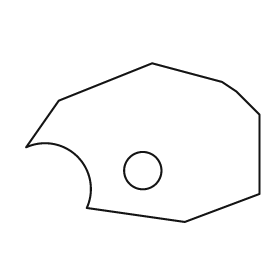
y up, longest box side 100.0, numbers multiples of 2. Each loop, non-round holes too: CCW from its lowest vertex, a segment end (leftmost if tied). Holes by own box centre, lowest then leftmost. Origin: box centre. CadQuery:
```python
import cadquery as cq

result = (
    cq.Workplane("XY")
    .moveTo(18.0, -34.0)
    .lineTo(50.0, -22.0)
    .lineTo(50.0, 12.0)
    .lineTo(40.0, 22.0)
    .lineTo(34.0, 26.0)
    .lineTo(4.0, 34.0)
    .lineTo(-36.0, 18.0)
    .lineTo(-50.0, -2.0)
    .threePointArc((-28.0, -6.0), (-24.0, -28.0))
    .close()
    .moveTo(0.0, -12.0)
    .circle(8.0)
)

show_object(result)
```